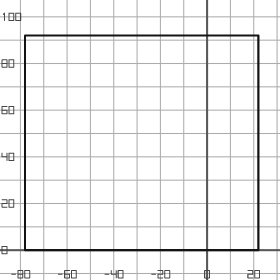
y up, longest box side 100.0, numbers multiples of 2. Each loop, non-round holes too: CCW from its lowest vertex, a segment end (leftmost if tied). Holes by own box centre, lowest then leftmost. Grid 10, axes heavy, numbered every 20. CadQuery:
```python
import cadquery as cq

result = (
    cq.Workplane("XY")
    .moveTo(-78.0, 0.0)
    .lineTo(22.0, 0.0)
    .lineTo(22.0, 92.0)
    .lineTo(-78.0, 92.0)
    .close()
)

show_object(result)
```